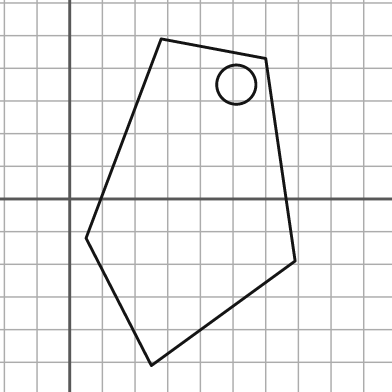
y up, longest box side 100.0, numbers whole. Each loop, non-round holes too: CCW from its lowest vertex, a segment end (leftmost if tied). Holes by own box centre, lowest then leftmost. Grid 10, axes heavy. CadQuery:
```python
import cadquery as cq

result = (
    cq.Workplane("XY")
    .moveTo(25.0, -51.0)
    .lineTo(69.0, -19.0)
    .lineTo(60.0, 43.0)
    .lineTo(28.0, 49.0)
    .lineTo(5.0, -12.0)
    .close()
    .moveTo(51.0, 35.0)
    .circle(6.0)
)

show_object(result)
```